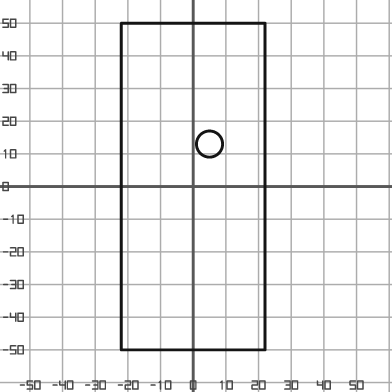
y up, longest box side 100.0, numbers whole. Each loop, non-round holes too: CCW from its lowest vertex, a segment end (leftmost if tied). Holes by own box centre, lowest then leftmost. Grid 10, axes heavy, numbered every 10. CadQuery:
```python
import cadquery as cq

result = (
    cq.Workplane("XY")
    .moveTo(-22.0, -50.0)
    .lineTo(22.0, -50.0)
    .lineTo(22.0, 50.0)
    .lineTo(-22.0, 50.0)
    .close()
    .moveTo(5.0, 13.0)
    .circle(4.0)
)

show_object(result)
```